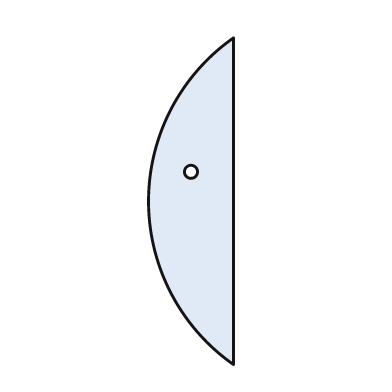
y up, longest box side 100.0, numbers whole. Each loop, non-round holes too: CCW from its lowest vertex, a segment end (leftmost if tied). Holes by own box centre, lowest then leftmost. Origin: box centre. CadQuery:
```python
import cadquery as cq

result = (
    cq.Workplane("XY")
    .moveTo(13.0, -50.0)
    .lineTo(13.0, 50.0)
    .threePointArc((-13.0, 0.0), (13.0, -50.0))
    .close()
    .moveTo(0.0, 9.0)
    .circle(2.0)
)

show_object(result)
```